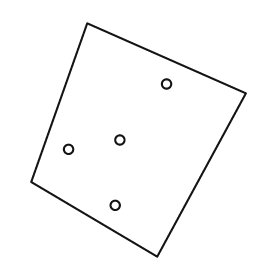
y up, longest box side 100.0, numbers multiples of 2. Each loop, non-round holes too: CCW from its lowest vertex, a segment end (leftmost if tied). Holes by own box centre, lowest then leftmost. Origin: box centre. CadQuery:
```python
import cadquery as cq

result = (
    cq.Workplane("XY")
    .moveTo(8.0, -50.0)
    .lineTo(46.0, 20.0)
    .lineTo(-22.0, 50.0)
    .lineTo(-46.0, -18.0)
    .close()
    .moveTo(-10.0, -28.0)
    .circle(2.0)
    .moveTo(-30.0, -4.0)
    .circle(2.0)
    .moveTo(-8.0, 0.0)
    .circle(2.0)
    .moveTo(12.0, 24.0)
    .circle(2.0)
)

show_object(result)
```